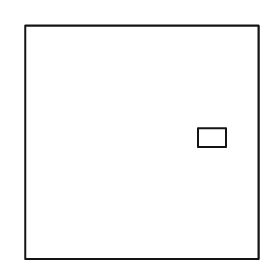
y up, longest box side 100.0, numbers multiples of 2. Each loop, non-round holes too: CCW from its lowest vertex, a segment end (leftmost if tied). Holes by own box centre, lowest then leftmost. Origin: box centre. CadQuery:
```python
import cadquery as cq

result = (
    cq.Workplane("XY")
    .moveTo(-50.0, -50.0)
    .lineTo(50.0, -50.0)
    .lineTo(50.0, 50.0)
    .lineTo(-50.0, 50.0)
    .close()
    .moveTo(24.0, -2.0)
    .lineTo(36.0, -2.0)
    .lineTo(36.0, 6.0)
    .lineTo(24.0, 6.0)
    .close()
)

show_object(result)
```